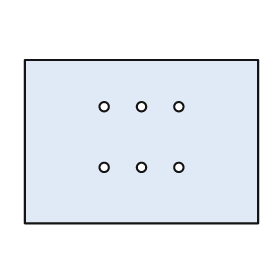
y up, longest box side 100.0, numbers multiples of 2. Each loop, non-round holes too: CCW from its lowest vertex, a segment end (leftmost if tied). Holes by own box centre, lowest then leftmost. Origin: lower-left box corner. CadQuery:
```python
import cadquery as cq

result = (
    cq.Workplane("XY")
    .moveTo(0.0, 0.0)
    .lineTo(100.0, 0.0)
    .lineTo(100.0, 70.0)
    .lineTo(0.0, 70.0)
    .close()
    .moveTo(34.0, 24.0)
    .circle(2.0)
    .moveTo(50.0, 24.0)
    .circle(2.0)
    .moveTo(66.0, 24.0)
    .circle(2.0)
    .moveTo(34.0, 50.0)
    .circle(2.0)
    .moveTo(50.0, 50.0)
    .circle(2.0)
    .moveTo(66.0, 50.0)
    .circle(2.0)
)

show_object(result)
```